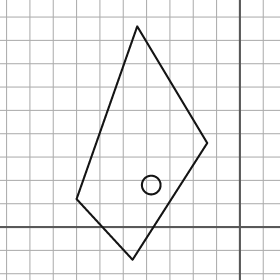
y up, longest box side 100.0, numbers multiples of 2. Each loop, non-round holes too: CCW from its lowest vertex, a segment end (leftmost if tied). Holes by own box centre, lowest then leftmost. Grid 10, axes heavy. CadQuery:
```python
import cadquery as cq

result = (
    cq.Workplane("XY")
    .moveTo(-46.0, -14.0)
    .lineTo(-14.0, 36.0)
    .lineTo(-44.0, 86.0)
    .lineTo(-70.0, 12.0)
    .close()
    .moveTo(-38.0, 18.0)
    .circle(4.0)
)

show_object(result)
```